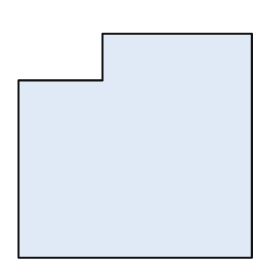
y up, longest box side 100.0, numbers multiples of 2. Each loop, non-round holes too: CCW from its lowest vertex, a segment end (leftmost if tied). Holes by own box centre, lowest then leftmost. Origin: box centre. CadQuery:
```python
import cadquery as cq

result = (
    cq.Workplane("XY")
    .moveTo(-50.0, -48.0)
    .lineTo(50.0, -48.0)
    .lineTo(50.0, 48.0)
    .lineTo(-14.0, 48.0)
    .lineTo(-14.0, 28.0)
    .lineTo(-50.0, 28.0)
    .close()
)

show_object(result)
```